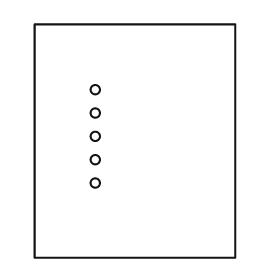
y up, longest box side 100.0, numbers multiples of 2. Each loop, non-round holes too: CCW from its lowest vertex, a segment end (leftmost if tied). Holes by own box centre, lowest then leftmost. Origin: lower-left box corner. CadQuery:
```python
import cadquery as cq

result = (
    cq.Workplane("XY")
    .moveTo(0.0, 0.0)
    .lineTo(86.0, 0.0)
    .lineTo(86.0, 100.0)
    .lineTo(0.0, 100.0)
    .close()
    .moveTo(26.0, 32.0)
    .circle(2.0)
    .moveTo(26.0, 42.0)
    .circle(2.0)
    .moveTo(26.0, 52.0)
    .circle(2.0)
    .moveTo(26.0, 62.0)
    .circle(2.0)
    .moveTo(26.0, 72.0)
    .circle(2.0)
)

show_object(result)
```